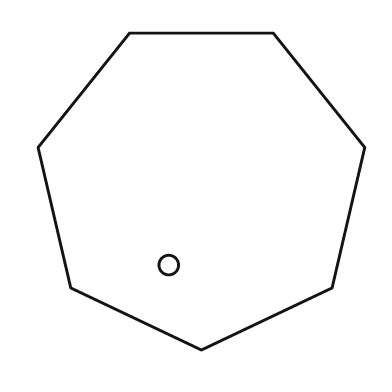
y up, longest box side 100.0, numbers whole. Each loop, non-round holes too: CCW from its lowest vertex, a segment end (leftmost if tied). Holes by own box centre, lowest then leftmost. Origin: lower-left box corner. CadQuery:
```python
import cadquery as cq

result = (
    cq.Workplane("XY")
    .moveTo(50.0, 0.0)
    .lineTo(90.0, 19.0)
    .lineTo(100.0, 62.0)
    .lineTo(72.0, 97.0)
    .lineTo(28.0, 97.0)
    .lineTo(0.0, 62.0)
    .lineTo(10.0, 19.0)
    .close()
    .moveTo(40.0, 26.0)
    .circle(3.0)
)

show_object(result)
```